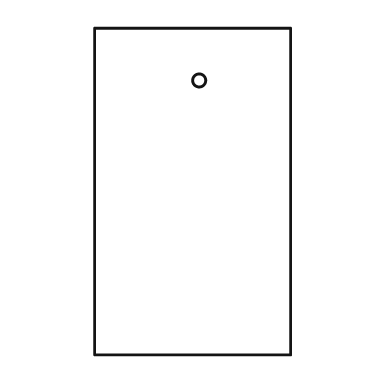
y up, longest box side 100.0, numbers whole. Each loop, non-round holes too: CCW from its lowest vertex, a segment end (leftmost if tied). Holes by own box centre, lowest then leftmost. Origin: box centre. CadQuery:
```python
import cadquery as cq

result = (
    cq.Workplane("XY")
    .moveTo(-30.0, -50.0)
    .lineTo(30.0, -50.0)
    .lineTo(30.0, 50.0)
    .lineTo(-30.0, 50.0)
    .close()
    .moveTo(2.0, 34.0)
    .circle(2.0)
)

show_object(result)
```